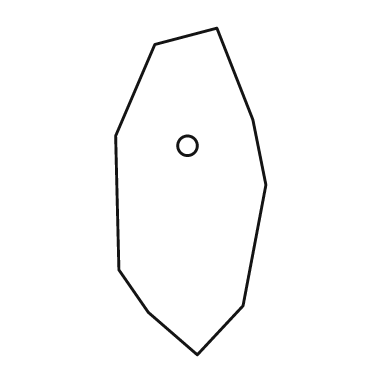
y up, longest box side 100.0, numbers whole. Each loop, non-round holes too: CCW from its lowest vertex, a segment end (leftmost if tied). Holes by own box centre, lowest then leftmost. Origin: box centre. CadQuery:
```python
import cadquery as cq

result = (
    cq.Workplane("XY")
    .moveTo(2.0, -50.0)
    .lineTo(16.0, -35.0)
    .lineTo(23.0, 2.0)
    .lineTo(19.0, 22.0)
    .lineTo(8.0, 50.0)
    .lineTo(-11.0, 45.0)
    .lineTo(-23.0, 17.0)
    .lineTo(-22.0, -24.0)
    .lineTo(-13.0, -37.0)
    .close()
    .moveTo(-1.0, 14.0)
    .circle(3.0)
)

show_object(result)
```